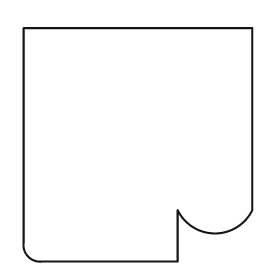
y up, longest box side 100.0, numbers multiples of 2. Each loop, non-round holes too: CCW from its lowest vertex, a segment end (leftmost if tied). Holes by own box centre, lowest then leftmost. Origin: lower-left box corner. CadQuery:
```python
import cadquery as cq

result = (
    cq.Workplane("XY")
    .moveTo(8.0, 0.0)
    .lineTo(66.0, 0.0)
    .lineTo(66.0, 22.0)
    .threePointArc((82.0, 12.0), (98.0, 22.0))
    .lineTo(98.0, 100.0)
    .lineTo(0.0, 100.0)
    .lineTo(0.0, 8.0)
    .threePointArc((2.0, 2.0), (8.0, 0.0))
    .close()
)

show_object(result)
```